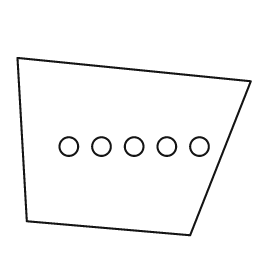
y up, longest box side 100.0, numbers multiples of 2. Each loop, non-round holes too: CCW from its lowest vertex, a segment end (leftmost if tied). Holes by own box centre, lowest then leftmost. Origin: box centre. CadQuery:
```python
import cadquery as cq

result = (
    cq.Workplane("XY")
    .moveTo(24.0, -38.0)
    .lineTo(50.0, 28.0)
    .lineTo(-50.0, 38.0)
    .lineTo(-46.0, -32.0)
    .close()
    .moveTo(-28.0, 0.0)
    .circle(4.0)
    .moveTo(-14.0, 0.0)
    .circle(4.0)
    .moveTo(0.0, 0.0)
    .circle(4.0)
    .moveTo(14.0, 0.0)
    .circle(4.0)
    .moveTo(28.0, 0.0)
    .circle(4.0)
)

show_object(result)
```